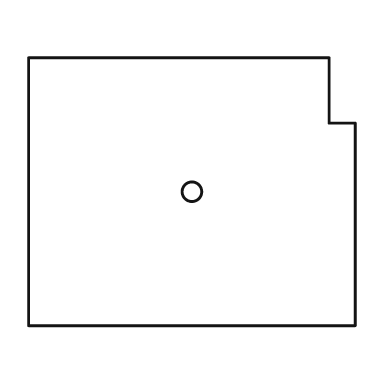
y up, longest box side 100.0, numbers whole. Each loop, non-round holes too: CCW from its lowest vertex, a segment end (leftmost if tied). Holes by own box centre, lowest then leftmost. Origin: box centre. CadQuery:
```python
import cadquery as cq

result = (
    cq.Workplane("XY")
    .moveTo(-50.0, -41.0)
    .lineTo(50.0, -41.0)
    .lineTo(50.0, 21.0)
    .lineTo(42.0, 21.0)
    .lineTo(42.0, 41.0)
    .lineTo(-50.0, 41.0)
    .close()
    .moveTo(0.0, 0.0)
    .circle(3.0)
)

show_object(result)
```